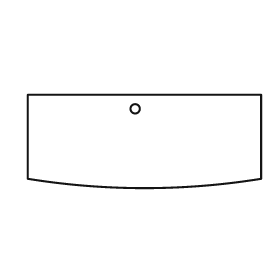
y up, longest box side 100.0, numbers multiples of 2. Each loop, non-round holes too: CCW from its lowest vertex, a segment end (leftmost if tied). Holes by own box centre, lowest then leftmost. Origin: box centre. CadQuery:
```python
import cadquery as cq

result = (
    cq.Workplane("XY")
    .moveTo(-50.0, -16.0)
    .threePointArc((0.0, -20.0), (50.0, -16.0))
    .lineTo(50.0, 20.0)
    .lineTo(-50.0, 20.0)
    .close()
    .moveTo(-4.0, 14.0)
    .circle(2.0)
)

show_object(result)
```